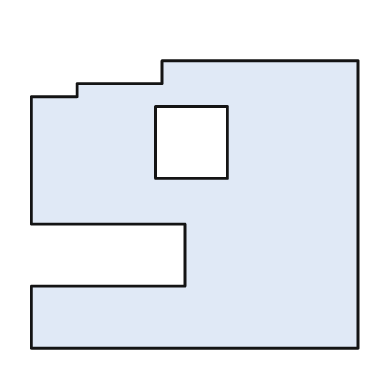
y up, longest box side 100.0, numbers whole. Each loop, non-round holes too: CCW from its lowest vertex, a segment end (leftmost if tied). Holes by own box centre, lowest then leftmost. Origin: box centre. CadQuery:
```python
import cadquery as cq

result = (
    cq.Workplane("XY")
    .moveTo(-50.0, -44.0)
    .lineTo(50.0, -44.0)
    .lineTo(50.0, 44.0)
    .lineTo(-10.0, 44.0)
    .lineTo(-10.0, 37.0)
    .lineTo(-36.0, 37.0)
    .lineTo(-36.0, 33.0)
    .lineTo(-50.0, 33.0)
    .lineTo(-50.0, -6.0)
    .lineTo(-3.0, -6.0)
    .lineTo(-3.0, -25.0)
    .lineTo(-50.0, -25.0)
    .close()
    .moveTo(-12.0, 8.0)
    .lineTo(10.0, 8.0)
    .lineTo(10.0, 30.0)
    .lineTo(-12.0, 30.0)
    .close()
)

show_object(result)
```